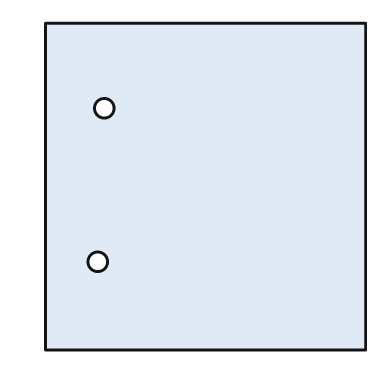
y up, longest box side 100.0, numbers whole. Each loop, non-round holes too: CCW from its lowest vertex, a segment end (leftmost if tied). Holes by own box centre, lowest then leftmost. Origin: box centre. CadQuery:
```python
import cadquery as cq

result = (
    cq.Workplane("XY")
    .moveTo(-49.0, -50.0)
    .lineTo(49.0, -50.0)
    .lineTo(49.0, 50.0)
    .lineTo(-49.0, 50.0)
    .close()
    .moveTo(-33.0, -23.0)
    .circle(3.0)
    .moveTo(-31.0, 24.0)
    .circle(3.0)
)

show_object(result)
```